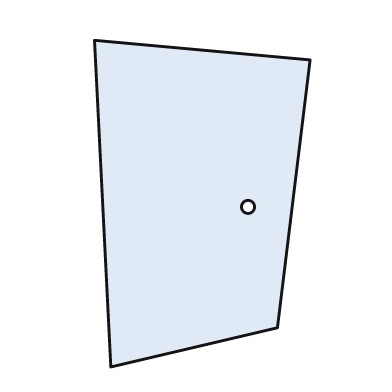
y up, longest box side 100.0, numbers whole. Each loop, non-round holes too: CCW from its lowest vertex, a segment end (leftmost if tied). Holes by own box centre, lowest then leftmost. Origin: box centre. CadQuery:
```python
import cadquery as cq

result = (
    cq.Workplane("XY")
    .moveTo(-28.0, -50.0)
    .lineTo(23.0, -38.0)
    .lineTo(33.0, 44.0)
    .lineTo(-33.0, 50.0)
    .close()
    .moveTo(14.0, -1.0)
    .circle(2.0)
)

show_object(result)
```